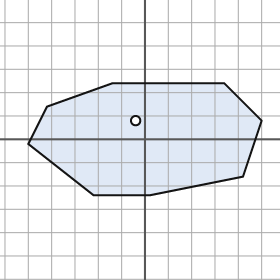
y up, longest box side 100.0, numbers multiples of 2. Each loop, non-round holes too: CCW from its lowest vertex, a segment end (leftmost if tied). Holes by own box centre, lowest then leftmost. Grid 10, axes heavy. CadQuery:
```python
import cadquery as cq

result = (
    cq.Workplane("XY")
    .moveTo(-22.0, -24.0)
    .lineTo(2.0, -24.0)
    .lineTo(42.0, -16.0)
    .lineTo(50.0, 8.0)
    .lineTo(34.0, 24.0)
    .lineTo(-14.0, 24.0)
    .lineTo(-42.0, 14.0)
    .lineTo(-50.0, -2.0)
    .close()
    .moveTo(-4.0, 8.0)
    .circle(2.0)
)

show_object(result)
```